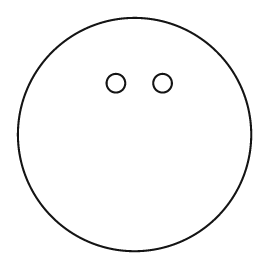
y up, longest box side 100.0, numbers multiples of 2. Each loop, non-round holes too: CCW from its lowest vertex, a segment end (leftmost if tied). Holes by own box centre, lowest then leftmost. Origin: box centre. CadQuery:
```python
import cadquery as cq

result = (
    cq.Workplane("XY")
    .moveTo(0.0, 0.0)
    .circle(50.0)
    .moveTo(-8.0, 22.0)
    .circle(4.0)
    .moveTo(12.0, 22.0)
    .circle(4.0)
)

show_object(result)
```